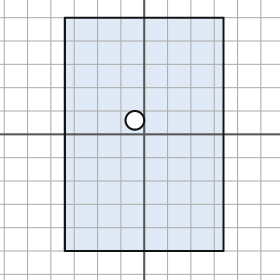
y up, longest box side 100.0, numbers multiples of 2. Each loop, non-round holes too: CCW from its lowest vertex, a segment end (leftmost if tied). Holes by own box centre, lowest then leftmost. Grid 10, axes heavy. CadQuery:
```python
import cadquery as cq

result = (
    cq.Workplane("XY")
    .moveTo(-34.0, -50.0)
    .lineTo(34.0, -50.0)
    .lineTo(34.0, 50.0)
    .lineTo(-34.0, 50.0)
    .close()
    .moveTo(-4.0, 6.0)
    .circle(4.0)
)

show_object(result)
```